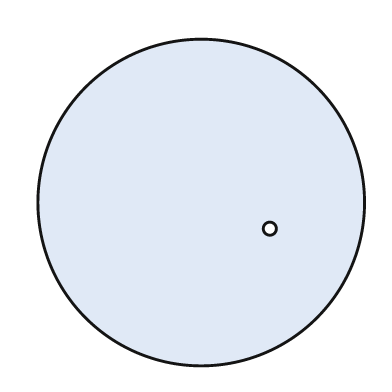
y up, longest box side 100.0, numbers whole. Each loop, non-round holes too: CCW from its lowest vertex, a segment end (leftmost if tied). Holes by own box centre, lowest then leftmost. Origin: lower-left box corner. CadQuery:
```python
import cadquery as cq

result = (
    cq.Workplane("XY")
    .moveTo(50.0, 50.0)
    .circle(50.0)
    .moveTo(71.0, 42.0)
    .circle(2.0)
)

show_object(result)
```